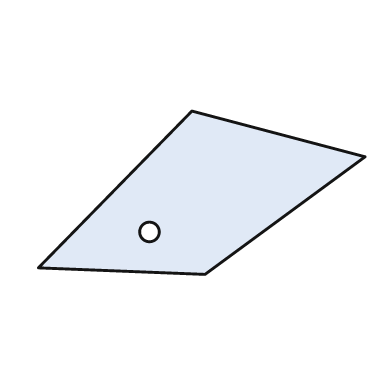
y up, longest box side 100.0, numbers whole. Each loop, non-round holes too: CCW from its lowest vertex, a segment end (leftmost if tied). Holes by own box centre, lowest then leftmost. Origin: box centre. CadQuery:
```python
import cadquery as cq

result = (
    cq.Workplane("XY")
    .moveTo(1.0, -25.0)
    .lineTo(50.0, 11.0)
    .lineTo(-3.0, 25.0)
    .lineTo(-50.0, -23.0)
    .close()
    .moveTo(-16.0, -12.0)
    .circle(3.0)
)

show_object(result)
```